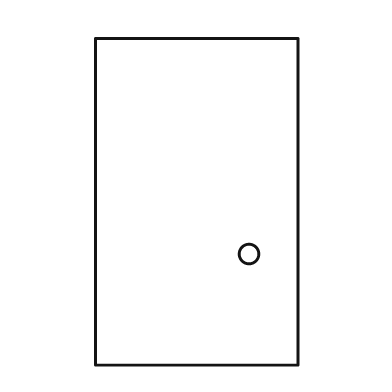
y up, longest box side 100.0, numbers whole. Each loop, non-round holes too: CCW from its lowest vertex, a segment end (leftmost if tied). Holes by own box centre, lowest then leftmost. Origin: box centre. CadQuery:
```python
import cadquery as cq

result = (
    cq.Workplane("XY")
    .moveTo(-31.0, -50.0)
    .lineTo(31.0, -50.0)
    .lineTo(31.0, 50.0)
    .lineTo(-31.0, 50.0)
    .close()
    .moveTo(16.0, -16.0)
    .circle(3.0)
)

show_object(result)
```